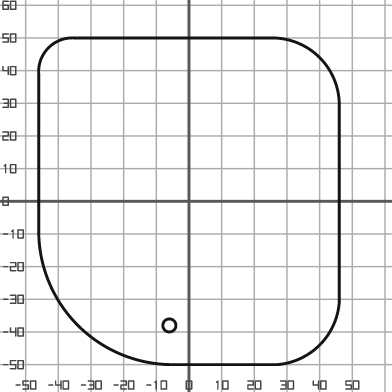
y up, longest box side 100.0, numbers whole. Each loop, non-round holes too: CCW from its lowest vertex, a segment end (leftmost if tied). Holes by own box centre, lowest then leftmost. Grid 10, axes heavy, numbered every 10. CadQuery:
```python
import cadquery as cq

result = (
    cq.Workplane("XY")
    .moveTo(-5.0, -50.0)
    .lineTo(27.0, -50.0)
    .threePointArc((40.0, -44.0), (46.0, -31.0))
    .lineTo(46.0, 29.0)
    .threePointArc((40.0, 44.0), (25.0, 50.0))
    .lineTo(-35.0, 50.0)
    .threePointArc((-43.0, 47.0), (-46.0, 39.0))
    .lineTo(-46.0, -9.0)
    .threePointArc((-34.0, -38.0), (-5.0, -50.0))
    .close()
    .moveTo(-6.0, -38.0)
    .circle(2.0)
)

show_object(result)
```